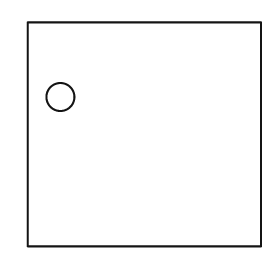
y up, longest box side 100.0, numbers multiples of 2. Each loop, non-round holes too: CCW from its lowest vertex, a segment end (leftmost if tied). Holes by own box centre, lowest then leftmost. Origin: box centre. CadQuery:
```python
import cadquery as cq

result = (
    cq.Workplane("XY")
    .moveTo(-50.0, -48.0)
    .lineTo(50.0, -48.0)
    .lineTo(50.0, 48.0)
    .lineTo(-50.0, 48.0)
    .close()
    .moveTo(-36.0, 16.0)
    .circle(6.0)
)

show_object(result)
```